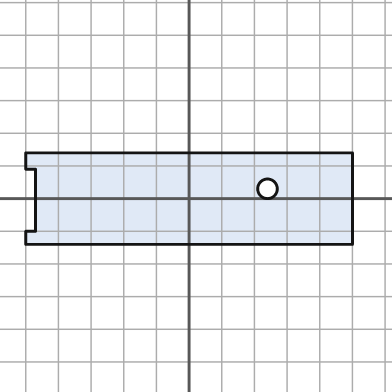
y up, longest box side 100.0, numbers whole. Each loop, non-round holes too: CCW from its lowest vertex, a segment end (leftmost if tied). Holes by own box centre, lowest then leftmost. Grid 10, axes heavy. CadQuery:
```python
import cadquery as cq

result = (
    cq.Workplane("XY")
    .moveTo(-50.0, -14.0)
    .lineTo(50.0, -14.0)
    .lineTo(50.0, 14.0)
    .lineTo(-50.0, 14.0)
    .lineTo(-50.0, 9.0)
    .lineTo(-47.0, 9.0)
    .lineTo(-47.0, -10.0)
    .lineTo(-50.0, -10.0)
    .close()
    .moveTo(24.0, 3.0)
    .circle(3.0)
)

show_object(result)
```